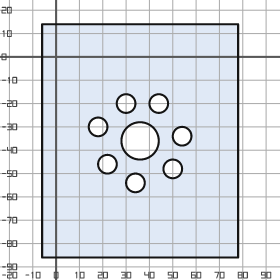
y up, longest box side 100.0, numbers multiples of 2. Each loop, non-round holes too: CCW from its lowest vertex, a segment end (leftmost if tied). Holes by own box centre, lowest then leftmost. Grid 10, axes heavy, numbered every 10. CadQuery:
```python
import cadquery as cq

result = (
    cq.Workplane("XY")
    .moveTo(-6.0, -86.0)
    .lineTo(78.0, -86.0)
    .lineTo(78.0, 14.0)
    .lineTo(-6.0, 14.0)
    .close()
    .moveTo(34.0, -54.0)
    .circle(4.0)
    .moveTo(50.0, -48.0)
    .circle(4.0)
    .moveTo(22.0, -46.0)
    .circle(4.0)
    .moveTo(36.0, -36.0)
    .circle(8.0)
    .moveTo(54.0, -34.0)
    .circle(4.0)
    .moveTo(18.0, -30.0)
    .circle(4.0)
    .moveTo(30.0, -20.0)
    .circle(4.0)
    .moveTo(44.0, -20.0)
    .circle(4.0)
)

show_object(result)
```